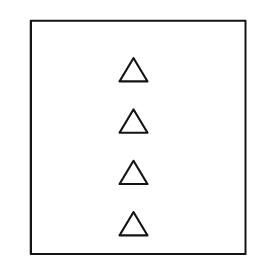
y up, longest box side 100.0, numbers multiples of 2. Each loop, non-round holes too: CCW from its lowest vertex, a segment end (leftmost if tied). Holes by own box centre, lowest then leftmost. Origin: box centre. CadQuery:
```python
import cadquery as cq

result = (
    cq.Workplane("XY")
    .moveTo(-46.0, -50.0)
    .lineTo(46.0, -50.0)
    .lineTo(46.0, 50.0)
    .lineTo(-46.0, 50.0)
    .close()
    .moveTo(-8.0, -42.0)
    .lineTo(4.0, -42.0)
    .lineTo(-2.0, -32.0)
    .close()
    .moveTo(-8.0, -20.0)
    .lineTo(4.0, -20.0)
    .lineTo(-2.0, -10.0)
    .close()
    .moveTo(-8.0, 2.0)
    .lineTo(4.0, 2.0)
    .lineTo(-2.0, 12.0)
    .close()
    .moveTo(-8.0, 24.0)
    .lineTo(4.0, 24.0)
    .lineTo(-2.0, 34.0)
    .close()
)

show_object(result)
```